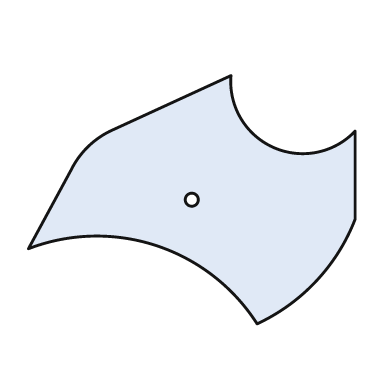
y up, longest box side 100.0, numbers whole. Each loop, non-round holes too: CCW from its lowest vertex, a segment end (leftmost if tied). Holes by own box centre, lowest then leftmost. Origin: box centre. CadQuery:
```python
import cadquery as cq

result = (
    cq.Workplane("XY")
    .moveTo(20.0, -38.0)
    .threePointArc((38.0, -25.0), (50.0, -6.0))
    .lineTo(50.0, 21.0)
    .threePointArc((25.0, 16.0), (12.0, 38.0))
    .lineTo(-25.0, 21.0)
    .threePointArc((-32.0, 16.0), (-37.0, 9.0))
    .lineTo(-50.0, -15.0)
    .threePointArc((-11.0, -14.0), (20.0, -38.0))
    .close()
    .moveTo(0.0, 0.0)
    .circle(2.0)
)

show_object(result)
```